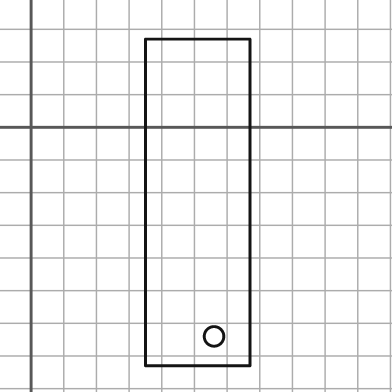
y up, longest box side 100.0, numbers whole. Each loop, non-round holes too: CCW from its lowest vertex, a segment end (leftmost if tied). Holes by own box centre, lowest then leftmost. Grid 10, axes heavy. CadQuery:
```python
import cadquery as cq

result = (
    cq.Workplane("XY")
    .moveTo(35.0, -73.0)
    .lineTo(67.0, -73.0)
    .lineTo(67.0, 27.0)
    .lineTo(35.0, 27.0)
    .close()
    .moveTo(56.0, -64.0)
    .circle(3.0)
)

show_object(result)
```